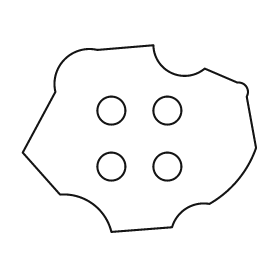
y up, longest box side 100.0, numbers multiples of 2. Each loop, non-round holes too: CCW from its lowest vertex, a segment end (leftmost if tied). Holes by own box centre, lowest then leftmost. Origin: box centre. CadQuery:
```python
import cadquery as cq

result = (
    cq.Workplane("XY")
    .moveTo(-12.0, -40.0)
    .lineTo(14.0, -38.0)
    .threePointArc((20.0, -30.0), (30.0, -28.0))
    .threePointArc((42.0, -18.0), (50.0, -4.0))
    .lineTo(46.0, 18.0)
    .threePointArc((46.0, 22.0), (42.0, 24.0))
    .lineTo(28.0, 30.0)
    .threePointArc((14.0, 28.0), (6.0, 40.0))
    .lineTo(-18.0, 38.0)
    .threePointArc((-32.0, 34.0), (-36.0, 20.0))
    .lineTo(-50.0, -6.0)
    .lineTo(-34.0, -24.0)
    .threePointArc((-20.0, -28.0), (-12.0, -40.0))
    .close()
    .moveTo(-12.0, -12.0)
    .circle(6.0)
    .moveTo(12.0, -12.0)
    .circle(6.0)
    .moveTo(-12.0, 12.0)
    .circle(6.0)
    .moveTo(12.0, 12.0)
    .circle(6.0)
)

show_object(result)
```